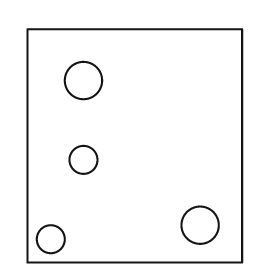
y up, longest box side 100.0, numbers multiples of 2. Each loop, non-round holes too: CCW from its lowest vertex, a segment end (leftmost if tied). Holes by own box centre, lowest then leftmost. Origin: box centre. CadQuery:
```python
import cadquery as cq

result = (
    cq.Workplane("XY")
    .moveTo(-46.0, -50.0)
    .lineTo(46.0, -50.0)
    .lineTo(46.0, 50.0)
    .lineTo(-46.0, 50.0)
    .close()
    .moveTo(-36.0, -40.0)
    .circle(6.0)
    .moveTo(28.0, -34.0)
    .circle(8.0)
    .moveTo(-22.0, -6.0)
    .circle(6.0)
    .moveTo(-22.0, 28.0)
    .circle(8.0)
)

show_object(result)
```